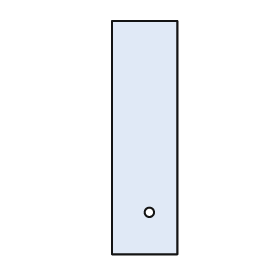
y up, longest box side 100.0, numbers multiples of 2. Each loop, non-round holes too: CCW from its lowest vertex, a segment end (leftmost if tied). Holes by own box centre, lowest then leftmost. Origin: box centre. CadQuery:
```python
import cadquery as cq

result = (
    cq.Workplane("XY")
    .moveTo(-14.0, -50.0)
    .lineTo(14.0, -50.0)
    .lineTo(14.0, 50.0)
    .lineTo(-14.0, 50.0)
    .close()
    .moveTo(2.0, -32.0)
    .circle(2.0)
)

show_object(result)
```